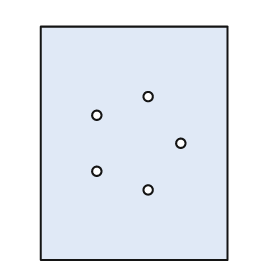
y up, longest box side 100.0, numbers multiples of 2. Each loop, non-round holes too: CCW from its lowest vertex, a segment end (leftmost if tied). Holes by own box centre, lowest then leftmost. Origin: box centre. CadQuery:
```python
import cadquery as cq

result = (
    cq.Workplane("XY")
    .moveTo(-40.0, -50.0)
    .lineTo(40.0, -50.0)
    .lineTo(40.0, 50.0)
    .lineTo(-40.0, 50.0)
    .close()
    .moveTo(6.0, -20.0)
    .circle(2.0)
    .moveTo(-16.0, -12.0)
    .circle(2.0)
    .moveTo(20.0, 0.0)
    .circle(2.0)
    .moveTo(-16.0, 12.0)
    .circle(2.0)
    .moveTo(6.0, 20.0)
    .circle(2.0)
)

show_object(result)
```